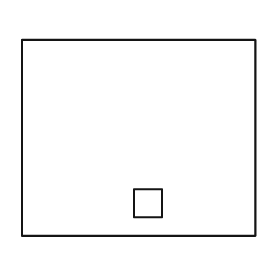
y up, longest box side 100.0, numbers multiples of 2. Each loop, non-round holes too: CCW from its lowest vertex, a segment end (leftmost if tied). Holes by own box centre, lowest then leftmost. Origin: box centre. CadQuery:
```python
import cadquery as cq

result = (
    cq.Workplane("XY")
    .moveTo(-50.0, -42.0)
    .lineTo(50.0, -42.0)
    .lineTo(50.0, 42.0)
    .lineTo(-50.0, 42.0)
    .close()
    .moveTo(-2.0, -34.0)
    .lineTo(10.0, -34.0)
    .lineTo(10.0, -22.0)
    .lineTo(-2.0, -22.0)
    .close()
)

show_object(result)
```